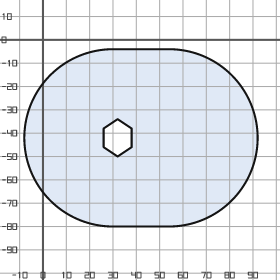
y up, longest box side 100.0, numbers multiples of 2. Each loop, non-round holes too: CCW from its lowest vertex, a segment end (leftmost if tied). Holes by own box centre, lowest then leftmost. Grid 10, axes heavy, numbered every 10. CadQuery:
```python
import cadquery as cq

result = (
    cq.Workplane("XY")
    .moveTo(30.0, -80.0)
    .lineTo(54.0, -80.0)
    .threePointArc((92.0, -42.0), (54.0, -4.0))
    .lineTo(30.0, -4.0)
    .threePointArc((-8.0, -42.0), (30.0, -80.0))
    .close()
    .moveTo(32.0, -50.0)
    .lineTo(38.0, -46.0)
    .lineTo(38.0, -38.0)
    .lineTo(32.0, -34.0)
    .lineTo(26.0, -38.0)
    .lineTo(26.0, -46.0)
    .close()
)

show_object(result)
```